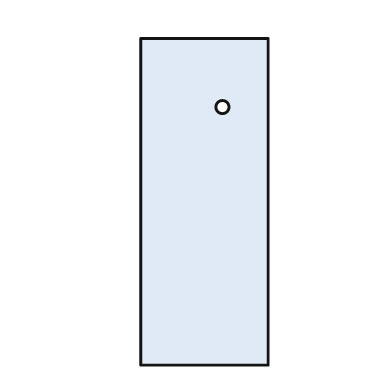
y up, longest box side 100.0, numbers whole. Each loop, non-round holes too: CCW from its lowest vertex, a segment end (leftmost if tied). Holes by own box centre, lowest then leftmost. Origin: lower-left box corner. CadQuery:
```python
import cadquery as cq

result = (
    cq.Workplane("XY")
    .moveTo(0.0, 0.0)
    .lineTo(39.0, 0.0)
    .lineTo(39.0, 100.0)
    .lineTo(0.0, 100.0)
    .close()
    .moveTo(25.0, 79.0)
    .circle(2.0)
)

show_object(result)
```